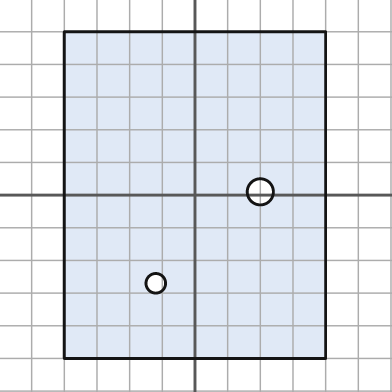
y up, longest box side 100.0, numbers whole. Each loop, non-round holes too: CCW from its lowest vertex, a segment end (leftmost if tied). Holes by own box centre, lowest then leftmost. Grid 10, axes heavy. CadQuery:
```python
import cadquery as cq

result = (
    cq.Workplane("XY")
    .moveTo(-40.0, -50.0)
    .lineTo(40.0, -50.0)
    .lineTo(40.0, 50.0)
    .lineTo(-40.0, 50.0)
    .close()
    .moveTo(-12.0, -27.0)
    .circle(3.0)
    .moveTo(20.0, 1.0)
    .circle(4.0)
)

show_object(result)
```